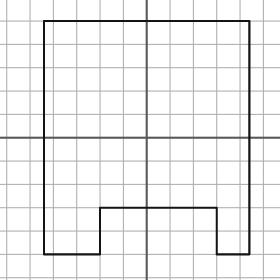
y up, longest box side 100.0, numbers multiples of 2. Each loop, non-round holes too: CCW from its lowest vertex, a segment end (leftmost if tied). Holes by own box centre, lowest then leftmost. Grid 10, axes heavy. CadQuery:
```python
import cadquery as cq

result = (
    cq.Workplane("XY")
    .moveTo(-44.0, -50.0)
    .lineTo(-20.0, -50.0)
    .lineTo(-20.0, -30.0)
    .lineTo(30.0, -30.0)
    .lineTo(30.0, -50.0)
    .lineTo(44.0, -50.0)
    .lineTo(44.0, 50.0)
    .lineTo(-44.0, 50.0)
    .close()
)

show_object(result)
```